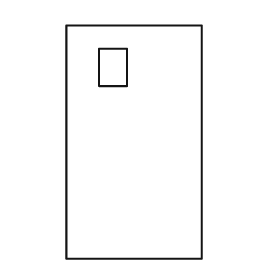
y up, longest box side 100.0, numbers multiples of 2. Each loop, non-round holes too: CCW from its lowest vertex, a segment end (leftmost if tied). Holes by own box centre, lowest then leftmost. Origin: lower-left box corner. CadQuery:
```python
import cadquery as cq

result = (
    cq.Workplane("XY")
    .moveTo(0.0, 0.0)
    .lineTo(58.0, 0.0)
    .lineTo(58.0, 100.0)
    .lineTo(0.0, 100.0)
    .close()
    .moveTo(14.0, 74.0)
    .lineTo(26.0, 74.0)
    .lineTo(26.0, 90.0)
    .lineTo(14.0, 90.0)
    .close()
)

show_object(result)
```